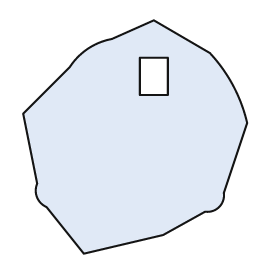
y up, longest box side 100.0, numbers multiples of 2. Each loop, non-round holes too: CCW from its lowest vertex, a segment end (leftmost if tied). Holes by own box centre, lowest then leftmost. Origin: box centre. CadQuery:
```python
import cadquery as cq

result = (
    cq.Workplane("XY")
    .moveTo(-22.0, -50.0)
    .lineTo(12.0, -42.0)
    .lineTo(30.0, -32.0)
    .threePointArc((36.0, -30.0), (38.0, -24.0))
    .lineTo(48.0, 6.0)
    .threePointArc((42.0, 22.0), (32.0, 36.0))
    .lineTo(8.0, 50.0)
    .lineTo(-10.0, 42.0)
    .threePointArc((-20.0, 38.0), (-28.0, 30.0))
    .lineTo(-48.0, 10.0)
    .lineTo(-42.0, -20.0)
    .threePointArc((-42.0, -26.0), (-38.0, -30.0))
    .close()
    .moveTo(2.0, 18.0)
    .lineTo(14.0, 18.0)
    .lineTo(14.0, 34.0)
    .lineTo(2.0, 34.0)
    .close()
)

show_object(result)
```